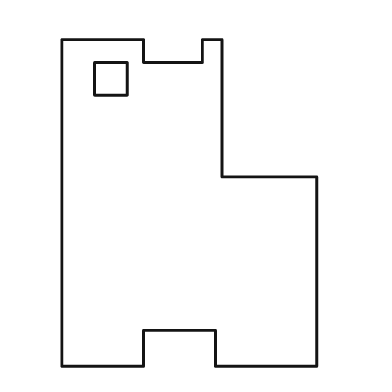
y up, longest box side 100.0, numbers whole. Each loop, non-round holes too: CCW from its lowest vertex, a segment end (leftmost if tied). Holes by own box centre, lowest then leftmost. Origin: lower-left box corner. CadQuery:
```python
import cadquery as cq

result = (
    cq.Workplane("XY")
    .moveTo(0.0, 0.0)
    .lineTo(25.0, 0.0)
    .lineTo(25.0, 11.0)
    .lineTo(47.0, 11.0)
    .lineTo(47.0, 0.0)
    .lineTo(78.0, 0.0)
    .lineTo(78.0, 58.0)
    .lineTo(49.0, 58.0)
    .lineTo(49.0, 100.0)
    .lineTo(43.0, 100.0)
    .lineTo(43.0, 93.0)
    .lineTo(25.0, 93.0)
    .lineTo(25.0, 100.0)
    .lineTo(0.0, 100.0)
    .close()
    .moveTo(10.0, 83.0)
    .lineTo(20.0, 83.0)
    .lineTo(20.0, 93.0)
    .lineTo(10.0, 93.0)
    .close()
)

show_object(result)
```